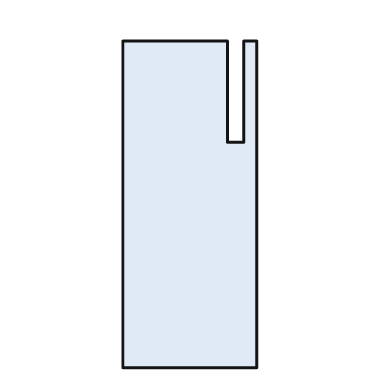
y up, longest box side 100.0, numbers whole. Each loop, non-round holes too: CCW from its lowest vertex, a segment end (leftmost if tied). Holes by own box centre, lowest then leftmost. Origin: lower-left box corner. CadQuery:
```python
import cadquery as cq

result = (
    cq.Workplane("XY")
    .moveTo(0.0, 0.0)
    .lineTo(41.0, 0.0)
    .lineTo(41.0, 100.0)
    .lineTo(37.0, 100.0)
    .lineTo(37.0, 69.0)
    .lineTo(32.0, 69.0)
    .lineTo(32.0, 100.0)
    .lineTo(0.0, 100.0)
    .close()
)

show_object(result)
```